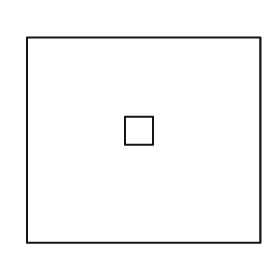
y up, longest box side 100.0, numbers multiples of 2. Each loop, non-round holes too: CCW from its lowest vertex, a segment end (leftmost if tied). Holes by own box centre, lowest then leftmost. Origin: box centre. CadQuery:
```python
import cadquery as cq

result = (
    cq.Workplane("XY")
    .moveTo(-50.0, -44.0)
    .lineTo(50.0, -44.0)
    .lineTo(50.0, 44.0)
    .lineTo(-50.0, 44.0)
    .close()
    .moveTo(-8.0, -2.0)
    .lineTo(4.0, -2.0)
    .lineTo(4.0, 10.0)
    .lineTo(-8.0, 10.0)
    .close()
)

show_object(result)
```